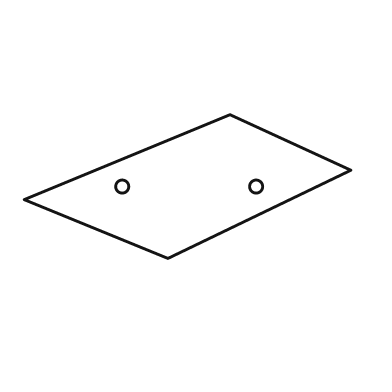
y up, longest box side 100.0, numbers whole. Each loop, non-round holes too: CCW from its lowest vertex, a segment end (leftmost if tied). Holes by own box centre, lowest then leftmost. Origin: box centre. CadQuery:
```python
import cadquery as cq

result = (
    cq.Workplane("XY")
    .moveTo(-6.0, -22.0)
    .lineTo(50.0, 5.0)
    .lineTo(13.0, 22.0)
    .lineTo(-50.0, -4.0)
    .close()
    .moveTo(-20.0, 0.0)
    .circle(2.0)
    .moveTo(21.0, 0.0)
    .circle(2.0)
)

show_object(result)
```